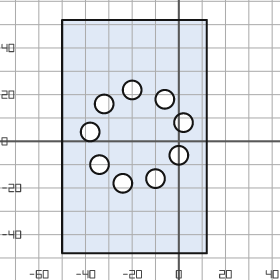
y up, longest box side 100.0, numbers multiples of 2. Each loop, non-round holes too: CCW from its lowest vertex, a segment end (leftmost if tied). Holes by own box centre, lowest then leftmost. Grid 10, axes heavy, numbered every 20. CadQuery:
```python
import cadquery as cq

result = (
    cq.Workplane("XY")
    .moveTo(-50.0, -48.0)
    .lineTo(12.0, -48.0)
    .lineTo(12.0, 52.0)
    .lineTo(-50.0, 52.0)
    .close()
    .moveTo(-24.0, -18.0)
    .circle(4.0)
    .moveTo(-10.0, -16.0)
    .circle(4.0)
    .moveTo(-34.0, -10.0)
    .circle(4.0)
    .moveTo(0.0, -6.0)
    .circle(4.0)
    .moveTo(-38.0, 4.0)
    .circle(4.0)
    .moveTo(2.0, 8.0)
    .circle(4.0)
    .moveTo(-32.0, 16.0)
    .circle(4.0)
    .moveTo(-6.0, 18.0)
    .circle(4.0)
    .moveTo(-20.0, 22.0)
    .circle(4.0)
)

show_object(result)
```